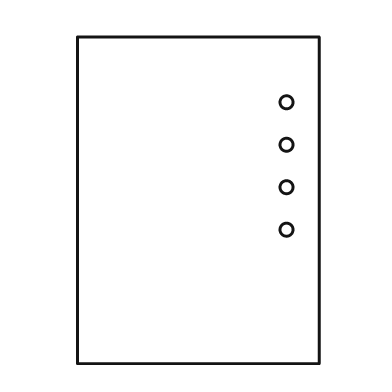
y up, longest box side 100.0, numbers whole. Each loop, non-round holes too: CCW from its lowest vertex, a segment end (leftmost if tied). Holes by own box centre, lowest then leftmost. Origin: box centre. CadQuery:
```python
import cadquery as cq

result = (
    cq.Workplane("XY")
    .moveTo(-37.0, -50.0)
    .lineTo(37.0, -50.0)
    .lineTo(37.0, 50.0)
    .lineTo(-37.0, 50.0)
    .close()
    .moveTo(27.0, -9.0)
    .circle(2.0)
    .moveTo(27.0, 4.0)
    .circle(2.0)
    .moveTo(27.0, 17.0)
    .circle(2.0)
    .moveTo(27.0, 30.0)
    .circle(2.0)
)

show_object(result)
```